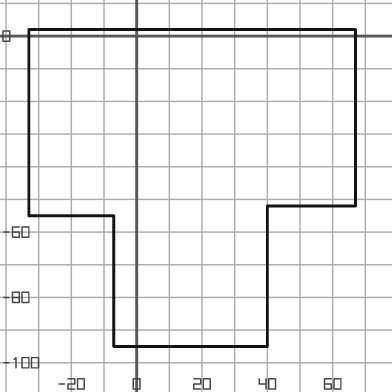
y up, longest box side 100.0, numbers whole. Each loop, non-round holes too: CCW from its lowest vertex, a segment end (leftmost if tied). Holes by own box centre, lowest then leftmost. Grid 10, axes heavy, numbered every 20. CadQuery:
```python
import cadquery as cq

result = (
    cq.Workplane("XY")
    .moveTo(-7.0, -95.0)
    .lineTo(40.0, -95.0)
    .lineTo(40.0, -52.0)
    .lineTo(67.0, -52.0)
    .lineTo(67.0, 2.0)
    .lineTo(-33.0, 2.0)
    .lineTo(-33.0, -55.0)
    .lineTo(-7.0, -55.0)
    .close()
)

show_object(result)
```